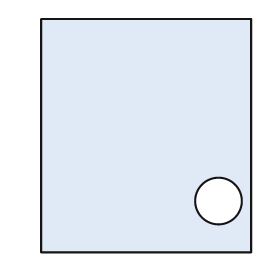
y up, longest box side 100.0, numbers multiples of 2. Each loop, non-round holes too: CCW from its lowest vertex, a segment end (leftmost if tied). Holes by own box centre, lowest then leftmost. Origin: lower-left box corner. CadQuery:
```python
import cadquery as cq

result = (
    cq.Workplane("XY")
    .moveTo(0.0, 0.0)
    .lineTo(90.0, 0.0)
    .lineTo(90.0, 100.0)
    .lineTo(0.0, 100.0)
    .close()
    .moveTo(76.0, 22.0)
    .circle(10.0)
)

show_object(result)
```